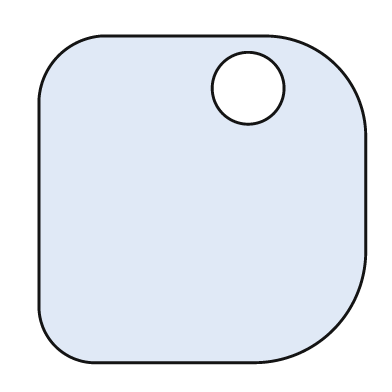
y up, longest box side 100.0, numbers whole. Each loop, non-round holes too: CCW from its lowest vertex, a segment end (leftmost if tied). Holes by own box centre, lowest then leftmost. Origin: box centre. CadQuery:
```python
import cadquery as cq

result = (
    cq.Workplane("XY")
    .moveTo(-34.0, -50.0)
    .lineTo(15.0, -50.0)
    .threePointArc((40.0, -40.0), (50.0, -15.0))
    .lineTo(50.0, 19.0)
    .threePointArc((41.0, 41.0), (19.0, 50.0))
    .lineTo(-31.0, 50.0)
    .threePointArc((-44.0, 44.0), (-50.0, 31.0))
    .lineTo(-50.0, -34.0)
    .threePointArc((-45.0, -45.0), (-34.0, -50.0))
    .close()
    .moveTo(14.0, 34.0)
    .circle(11.0)
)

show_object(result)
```